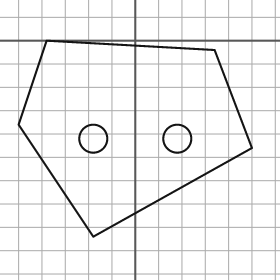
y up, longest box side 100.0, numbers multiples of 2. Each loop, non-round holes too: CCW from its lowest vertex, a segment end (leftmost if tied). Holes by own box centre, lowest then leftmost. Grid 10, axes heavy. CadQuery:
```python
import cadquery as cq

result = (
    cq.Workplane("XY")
    .moveTo(-18.0, -84.0)
    .lineTo(50.0, -46.0)
    .lineTo(34.0, -4.0)
    .lineTo(-38.0, 0.0)
    .lineTo(-50.0, -36.0)
    .close()
    .moveTo(-18.0, -42.0)
    .circle(6.0)
    .moveTo(18.0, -42.0)
    .circle(6.0)
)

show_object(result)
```